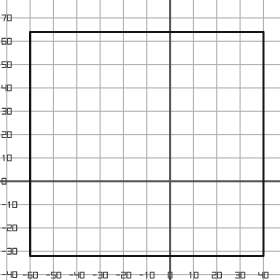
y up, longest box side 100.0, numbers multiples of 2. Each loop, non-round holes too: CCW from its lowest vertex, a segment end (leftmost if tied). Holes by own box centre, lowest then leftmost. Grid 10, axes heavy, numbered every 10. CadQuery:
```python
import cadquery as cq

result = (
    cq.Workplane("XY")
    .moveTo(-60.0, -32.0)
    .lineTo(40.0, -32.0)
    .lineTo(40.0, 64.0)
    .lineTo(-60.0, 64.0)
    .close()
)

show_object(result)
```